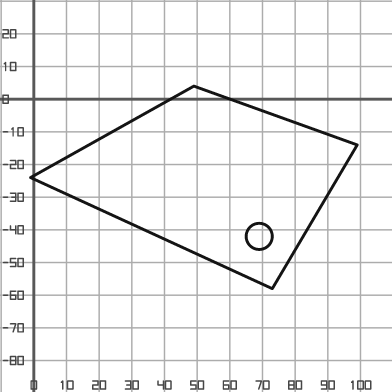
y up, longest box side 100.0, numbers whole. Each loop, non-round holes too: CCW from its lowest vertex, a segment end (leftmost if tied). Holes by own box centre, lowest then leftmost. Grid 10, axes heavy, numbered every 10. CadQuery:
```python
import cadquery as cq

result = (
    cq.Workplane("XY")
    .moveTo(73.0, -58.0)
    .lineTo(99.0, -14.0)
    .lineTo(49.0, 4.0)
    .lineTo(-1.0, -24.0)
    .close()
    .moveTo(69.0, -42.0)
    .circle(4.0)
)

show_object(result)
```